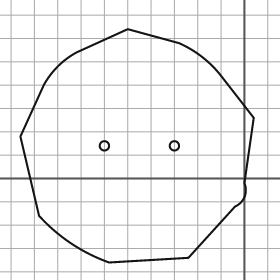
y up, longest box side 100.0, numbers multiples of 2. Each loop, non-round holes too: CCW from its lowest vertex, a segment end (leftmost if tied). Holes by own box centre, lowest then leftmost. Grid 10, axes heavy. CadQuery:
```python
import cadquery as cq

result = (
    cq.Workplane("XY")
    .moveTo(-58.0, -36.0)
    .lineTo(-24.0, -34.0)
    .lineTo(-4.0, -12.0)
    .threePointArc((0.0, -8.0), (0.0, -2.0))
    .lineTo(4.0, 26.0)
    .lineTo(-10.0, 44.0)
    .threePointArc((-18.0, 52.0), (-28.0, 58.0))
    .lineTo(-50.0, 64.0)
    .lineTo(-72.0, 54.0)
    .threePointArc((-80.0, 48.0), (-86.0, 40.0))
    .lineTo(-96.0, 18.0)
    .lineTo(-88.0, -16.0)
    .threePointArc((-74.0, -28.0), (-58.0, -36.0))
    .close()
    .moveTo(-60.0, 14.0)
    .circle(2.0)
    .moveTo(-30.0, 14.0)
    .circle(2.0)
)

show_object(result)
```